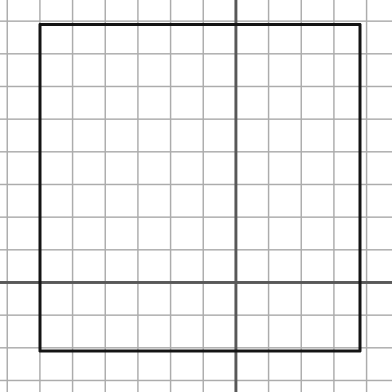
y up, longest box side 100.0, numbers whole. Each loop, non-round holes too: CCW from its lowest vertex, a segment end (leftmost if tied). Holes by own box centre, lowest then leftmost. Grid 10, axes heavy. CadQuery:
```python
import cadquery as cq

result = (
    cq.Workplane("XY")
    .moveTo(-60.0, -21.0)
    .lineTo(38.0, -21.0)
    .lineTo(38.0, 79.0)
    .lineTo(-60.0, 79.0)
    .close()
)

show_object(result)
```